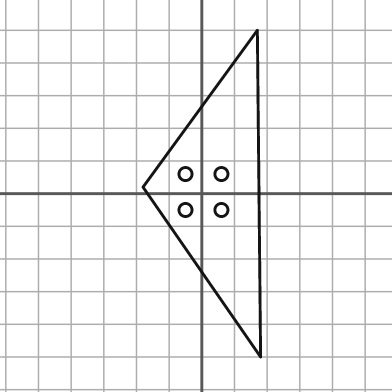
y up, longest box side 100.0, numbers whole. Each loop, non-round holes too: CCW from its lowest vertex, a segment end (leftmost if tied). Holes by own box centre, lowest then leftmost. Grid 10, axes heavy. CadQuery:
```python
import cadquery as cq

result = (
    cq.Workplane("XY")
    .moveTo(18.0, -50.0)
    .lineTo(17.0, 50.0)
    .lineTo(-18.0, 2.0)
    .close()
    .moveTo(-5.0, -5.0)
    .circle(2.0)
    .moveTo(6.0, -5.0)
    .circle(2.0)
    .moveTo(-5.0, 6.0)
    .circle(2.0)
    .moveTo(6.0, 6.0)
    .circle(2.0)
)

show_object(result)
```